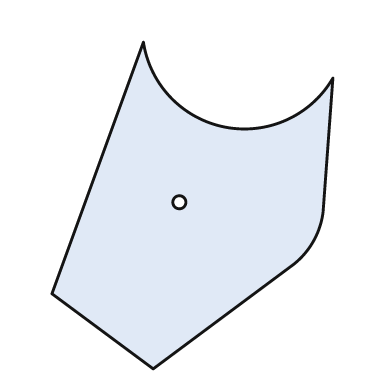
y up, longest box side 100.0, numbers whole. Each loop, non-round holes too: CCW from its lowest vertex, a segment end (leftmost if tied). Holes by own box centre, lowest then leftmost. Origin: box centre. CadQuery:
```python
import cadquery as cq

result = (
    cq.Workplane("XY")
    .moveTo(-12.0, -50.0)
    .lineTo(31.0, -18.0)
    .threePointArc((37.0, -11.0), (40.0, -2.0))
    .lineTo(43.0, 39.0)
    .threePointArc((10.0, 24.0), (-15.0, 50.0))
    .lineTo(-43.0, -27.0)
    .close()
    .moveTo(-4.0, 1.0)
    .circle(2.0)
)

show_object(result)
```